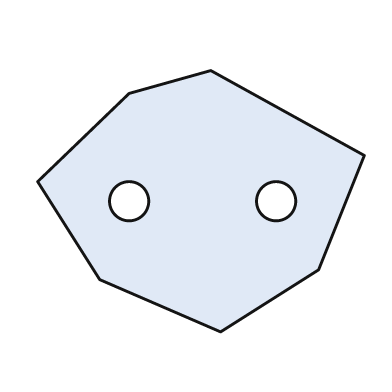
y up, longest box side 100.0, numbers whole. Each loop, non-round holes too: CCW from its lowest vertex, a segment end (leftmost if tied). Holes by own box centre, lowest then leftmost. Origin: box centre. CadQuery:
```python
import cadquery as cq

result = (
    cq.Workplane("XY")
    .moveTo(6.0, -40.0)
    .lineTo(36.0, -21.0)
    .lineTo(50.0, 14.0)
    .lineTo(3.0, 40.0)
    .lineTo(-22.0, 33.0)
    .lineTo(-50.0, 6.0)
    .lineTo(-31.0, -24.0)
    .close()
    .moveTo(-22.0, 0.0)
    .circle(6.0)
    .moveTo(23.0, 0.0)
    .circle(6.0)
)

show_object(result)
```